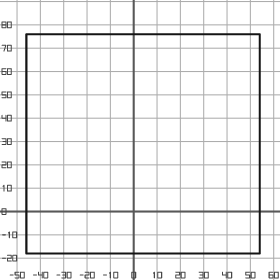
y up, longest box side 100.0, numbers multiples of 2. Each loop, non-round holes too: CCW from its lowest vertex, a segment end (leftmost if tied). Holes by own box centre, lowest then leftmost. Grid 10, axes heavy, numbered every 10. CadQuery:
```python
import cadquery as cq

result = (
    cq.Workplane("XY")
    .moveTo(-46.0, -18.0)
    .lineTo(54.0, -18.0)
    .lineTo(54.0, 76.0)
    .lineTo(-46.0, 76.0)
    .close()
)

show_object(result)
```